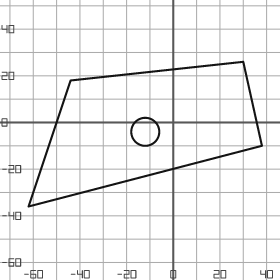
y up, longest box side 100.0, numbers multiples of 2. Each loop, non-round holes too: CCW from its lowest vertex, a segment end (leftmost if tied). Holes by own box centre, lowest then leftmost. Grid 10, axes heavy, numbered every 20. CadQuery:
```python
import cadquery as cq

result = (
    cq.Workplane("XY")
    .moveTo(-62.0, -36.0)
    .lineTo(38.0, -10.0)
    .lineTo(30.0, 26.0)
    .lineTo(-44.0, 18.0)
    .close()
    .moveTo(-12.0, -4.0)
    .circle(6.0)
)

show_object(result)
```